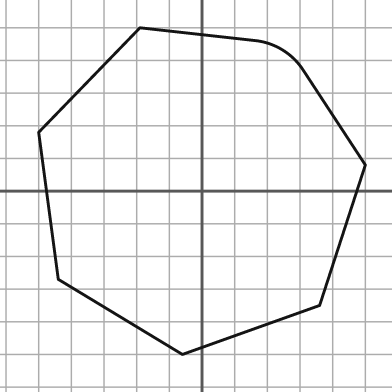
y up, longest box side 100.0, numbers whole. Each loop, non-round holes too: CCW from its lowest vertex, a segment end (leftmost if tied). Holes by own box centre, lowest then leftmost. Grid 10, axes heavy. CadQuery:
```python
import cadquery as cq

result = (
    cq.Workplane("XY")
    .moveTo(-6.0, -50.0)
    .lineTo(36.0, -35.0)
    .lineTo(50.0, 8.0)
    .lineTo(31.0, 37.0)
    .threePointArc((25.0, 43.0), (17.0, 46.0))
    .lineTo(-19.0, 50.0)
    .lineTo(-50.0, 18.0)
    .lineTo(-44.0, -27.0)
    .close()
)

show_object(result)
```